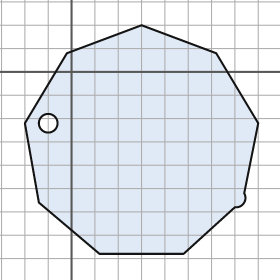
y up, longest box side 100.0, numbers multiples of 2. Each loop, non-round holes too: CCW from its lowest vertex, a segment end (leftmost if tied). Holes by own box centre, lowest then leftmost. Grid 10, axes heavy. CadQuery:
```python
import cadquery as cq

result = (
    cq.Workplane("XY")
    .moveTo(12.0, -78.0)
    .lineTo(48.0, -78.0)
    .lineTo(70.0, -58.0)
    .threePointArc((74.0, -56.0), (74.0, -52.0))
    .lineTo(80.0, -22.0)
    .lineTo(62.0, 8.0)
    .lineTo(30.0, 20.0)
    .lineTo(-2.0, 8.0)
    .lineTo(-20.0, -22.0)
    .lineTo(-14.0, -56.0)
    .close()
    .moveTo(-10.0, -22.0)
    .circle(4.0)
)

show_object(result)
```